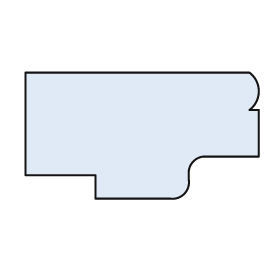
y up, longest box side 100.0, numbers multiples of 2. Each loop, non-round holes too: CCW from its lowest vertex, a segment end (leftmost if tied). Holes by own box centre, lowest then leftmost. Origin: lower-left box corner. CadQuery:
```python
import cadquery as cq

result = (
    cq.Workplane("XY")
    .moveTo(30.0, 0.0)
    .lineTo(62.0, 0.0)
    .threePointArc((68.0, 2.0), (70.0, 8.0))
    .lineTo(70.0, 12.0)
    .threePointArc((72.0, 16.0), (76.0, 18.0))
    .lineTo(100.0, 18.0)
    .lineTo(100.0, 38.0)
    .lineTo(96.0, 38.0)
    .threePointArc((100.0, 46.0), (96.0, 54.0))
    .lineTo(0.0, 54.0)
    .lineTo(0.0, 10.0)
    .lineTo(30.0, 10.0)
    .close()
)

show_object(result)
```